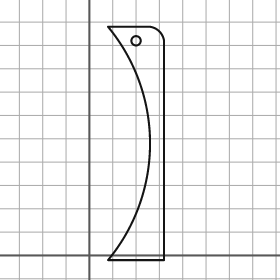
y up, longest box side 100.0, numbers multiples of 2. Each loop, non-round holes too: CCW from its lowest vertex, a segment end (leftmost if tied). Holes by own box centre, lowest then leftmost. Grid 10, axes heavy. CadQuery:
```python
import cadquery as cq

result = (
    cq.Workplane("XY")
    .moveTo(8.0, -2.0)
    .lineTo(32.0, -2.0)
    .lineTo(32.0, 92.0)
    .threePointArc((30.0, 96.0), (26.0, 98.0))
    .lineTo(8.0, 98.0)
    .threePointArc((26.0, 48.0), (8.0, -2.0))
    .close()
    .moveTo(20.0, 92.0)
    .circle(2.0)
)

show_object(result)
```